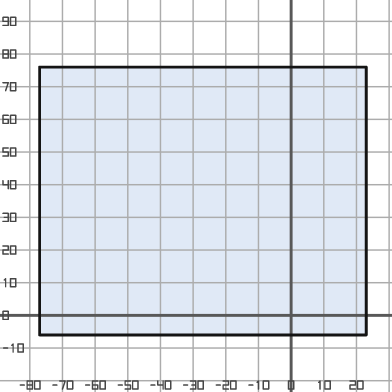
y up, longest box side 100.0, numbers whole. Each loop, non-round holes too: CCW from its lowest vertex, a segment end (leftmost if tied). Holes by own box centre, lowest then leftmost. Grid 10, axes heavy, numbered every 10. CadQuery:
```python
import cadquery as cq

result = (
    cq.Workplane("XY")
    .moveTo(-77.0, -6.0)
    .lineTo(23.0, -6.0)
    .lineTo(23.0, 76.0)
    .lineTo(-77.0, 76.0)
    .close()
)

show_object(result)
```